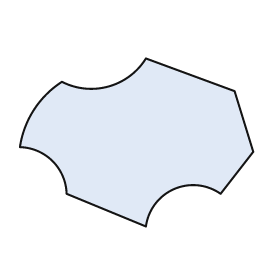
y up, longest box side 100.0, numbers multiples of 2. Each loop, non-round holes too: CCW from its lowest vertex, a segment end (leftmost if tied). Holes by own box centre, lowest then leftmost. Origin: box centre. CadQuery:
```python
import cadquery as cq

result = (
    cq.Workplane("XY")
    .moveTo(4.0, -36.0)
    .threePointArc((16.0, -20.0), (36.0, -22.0))
    .lineTo(50.0, -4.0)
    .lineTo(42.0, 22.0)
    .lineTo(4.0, 36.0)
    .threePointArc((-12.0, 24.0), (-32.0, 26.0))
    .threePointArc((-44.0, 14.0), (-50.0, -2.0))
    .threePointArc((-36.0, -8.0), (-30.0, -22.0))
    .close()
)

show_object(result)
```